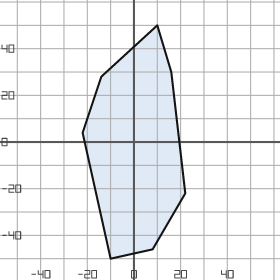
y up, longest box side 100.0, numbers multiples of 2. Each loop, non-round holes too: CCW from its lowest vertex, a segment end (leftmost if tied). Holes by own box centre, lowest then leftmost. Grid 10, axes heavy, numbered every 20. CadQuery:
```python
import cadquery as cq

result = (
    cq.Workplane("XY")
    .moveTo(-10.0, -50.0)
    .lineTo(8.0, -46.0)
    .lineTo(22.0, -22.0)
    .lineTo(16.0, 30.0)
    .lineTo(10.0, 50.0)
    .lineTo(-14.0, 28.0)
    .lineTo(-22.0, 4.0)
    .close()
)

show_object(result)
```